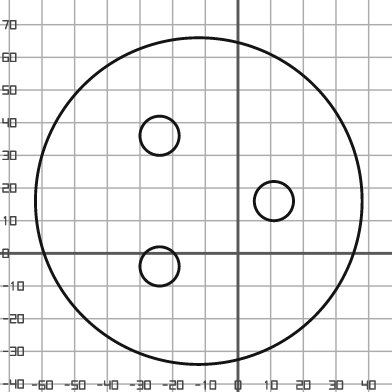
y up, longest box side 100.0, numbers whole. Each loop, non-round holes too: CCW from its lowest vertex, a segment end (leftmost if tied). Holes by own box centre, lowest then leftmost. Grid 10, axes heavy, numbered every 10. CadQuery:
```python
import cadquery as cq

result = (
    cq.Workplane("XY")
    .moveTo(-12.0, 16.0)
    .circle(50.0)
    .moveTo(-24.0, -4.0)
    .circle(6.0)
    .moveTo(11.0, 16.0)
    .circle(6.0)
    .moveTo(-24.0, 36.0)
    .circle(6.0)
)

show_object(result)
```